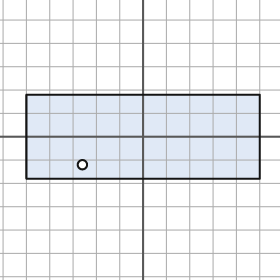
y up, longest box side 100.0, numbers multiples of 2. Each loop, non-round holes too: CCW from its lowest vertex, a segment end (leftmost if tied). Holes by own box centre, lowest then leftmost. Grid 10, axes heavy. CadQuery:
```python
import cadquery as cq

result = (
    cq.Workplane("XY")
    .moveTo(-50.0, -18.0)
    .lineTo(50.0, -18.0)
    .lineTo(50.0, 18.0)
    .lineTo(-50.0, 18.0)
    .close()
    .moveTo(-26.0, -12.0)
    .circle(2.0)
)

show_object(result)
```